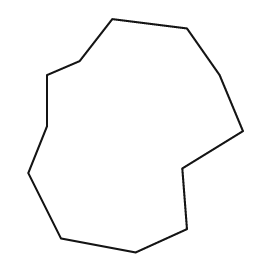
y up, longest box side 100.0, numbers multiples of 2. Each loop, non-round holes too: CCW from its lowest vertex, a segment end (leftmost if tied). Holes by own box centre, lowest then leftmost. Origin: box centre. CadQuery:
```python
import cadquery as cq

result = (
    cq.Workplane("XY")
    .moveTo(0.0, -50.0)
    .lineTo(22.0, -40.0)
    .lineTo(20.0, -14.0)
    .lineTo(46.0, 2.0)
    .lineTo(36.0, 26.0)
    .lineTo(22.0, 46.0)
    .lineTo(-10.0, 50.0)
    .lineTo(-24.0, 32.0)
    .lineTo(-38.0, 26.0)
    .lineTo(-38.0, 4.0)
    .lineTo(-46.0, -16.0)
    .lineTo(-32.0, -44.0)
    .close()
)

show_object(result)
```